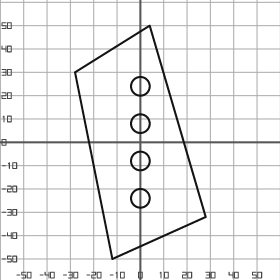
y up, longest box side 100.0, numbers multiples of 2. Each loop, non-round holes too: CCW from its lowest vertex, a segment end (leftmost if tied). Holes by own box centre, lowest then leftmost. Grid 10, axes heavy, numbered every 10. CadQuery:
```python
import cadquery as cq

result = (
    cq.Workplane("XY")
    .moveTo(-12.0, -50.0)
    .lineTo(28.0, -32.0)
    .lineTo(4.0, 50.0)
    .lineTo(-28.0, 30.0)
    .close()
    .moveTo(0.0, -24.0)
    .circle(4.0)
    .moveTo(0.0, -8.0)
    .circle(4.0)
    .moveTo(0.0, 8.0)
    .circle(4.0)
    .moveTo(0.0, 24.0)
    .circle(4.0)
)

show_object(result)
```